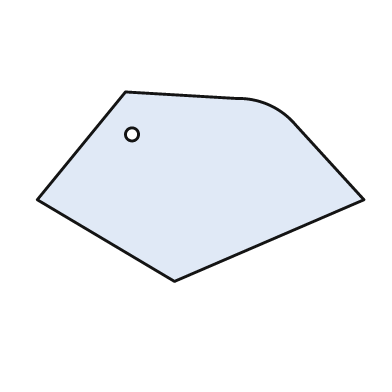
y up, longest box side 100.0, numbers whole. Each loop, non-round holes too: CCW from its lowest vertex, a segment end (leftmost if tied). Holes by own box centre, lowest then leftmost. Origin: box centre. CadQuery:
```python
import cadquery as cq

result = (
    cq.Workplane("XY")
    .moveTo(-8.0, -29.0)
    .lineTo(50.0, -4.0)
    .lineTo(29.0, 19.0)
    .threePointArc((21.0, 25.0), (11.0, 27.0))
    .lineTo(-23.0, 29.0)
    .lineTo(-50.0, -4.0)
    .close()
    .moveTo(-21.0, 16.0)
    .circle(2.0)
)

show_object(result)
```